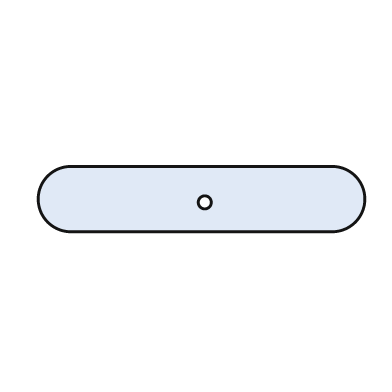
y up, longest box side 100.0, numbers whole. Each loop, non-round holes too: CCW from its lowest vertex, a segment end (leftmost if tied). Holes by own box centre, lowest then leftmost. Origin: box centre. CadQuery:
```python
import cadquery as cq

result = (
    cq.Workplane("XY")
    .moveTo(-40.0, -10.0)
    .lineTo(40.0, -10.0)
    .threePointArc((50.0, 0.0), (40.0, 10.0))
    .lineTo(-40.0, 10.0)
    .threePointArc((-50.0, 0.0), (-40.0, -10.0))
    .close()
    .moveTo(1.0, -1.0)
    .circle(2.0)
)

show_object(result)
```